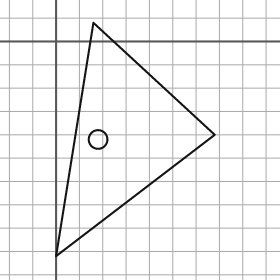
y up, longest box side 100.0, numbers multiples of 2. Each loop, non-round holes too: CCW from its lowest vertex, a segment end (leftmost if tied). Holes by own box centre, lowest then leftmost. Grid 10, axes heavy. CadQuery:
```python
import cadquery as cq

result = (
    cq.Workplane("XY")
    .moveTo(0.0, -92.0)
    .lineTo(68.0, -40.0)
    .lineTo(16.0, 8.0)
    .close()
    .moveTo(18.0, -42.0)
    .circle(4.0)
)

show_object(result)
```